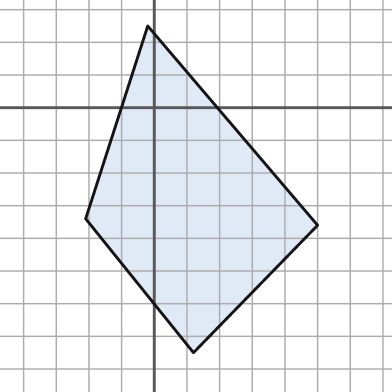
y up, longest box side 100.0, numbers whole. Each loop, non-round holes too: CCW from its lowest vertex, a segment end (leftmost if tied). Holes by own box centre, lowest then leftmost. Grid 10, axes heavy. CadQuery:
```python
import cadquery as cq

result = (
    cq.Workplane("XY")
    .moveTo(12.0, -75.0)
    .lineTo(50.0, -36.0)
    .lineTo(-2.0, 25.0)
    .lineTo(-21.0, -34.0)
    .close()
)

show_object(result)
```